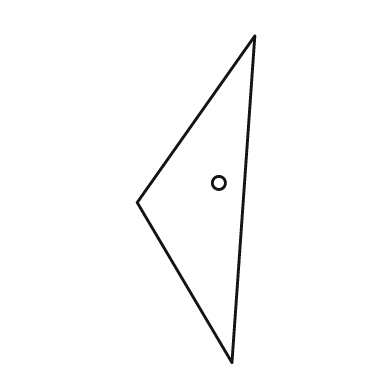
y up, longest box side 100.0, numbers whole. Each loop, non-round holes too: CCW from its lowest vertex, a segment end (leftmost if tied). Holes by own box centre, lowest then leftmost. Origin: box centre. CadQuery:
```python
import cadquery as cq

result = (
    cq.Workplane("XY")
    .moveTo(11.0, -50.0)
    .lineTo(18.0, 50.0)
    .lineTo(-18.0, -1.0)
    .close()
    .moveTo(7.0, 5.0)
    .circle(2.0)
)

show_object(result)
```